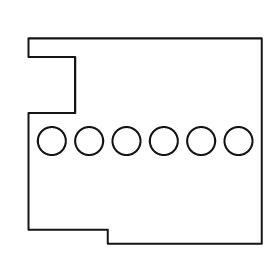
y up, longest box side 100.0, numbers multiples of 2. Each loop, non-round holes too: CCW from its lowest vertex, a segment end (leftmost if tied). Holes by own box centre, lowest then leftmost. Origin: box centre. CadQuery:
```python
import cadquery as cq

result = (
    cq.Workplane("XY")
    .moveTo(-16.0, -44.0)
    .lineTo(50.0, -44.0)
    .lineTo(50.0, 44.0)
    .lineTo(-50.0, 44.0)
    .lineTo(-50.0, 36.0)
    .lineTo(-30.0, 36.0)
    .lineTo(-30.0, 12.0)
    .lineTo(-50.0, 12.0)
    .lineTo(-50.0, -38.0)
    .lineTo(-16.0, -38.0)
    .close()
    .moveTo(-40.0, 0.0)
    .circle(6.0)
    .moveTo(-24.0, 0.0)
    .circle(6.0)
    .moveTo(-8.0, 0.0)
    .circle(6.0)
    .moveTo(8.0, 0.0)
    .circle(6.0)
    .moveTo(24.0, 0.0)
    .circle(6.0)
    .moveTo(40.0, 0.0)
    .circle(6.0)
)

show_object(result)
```